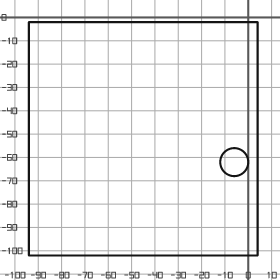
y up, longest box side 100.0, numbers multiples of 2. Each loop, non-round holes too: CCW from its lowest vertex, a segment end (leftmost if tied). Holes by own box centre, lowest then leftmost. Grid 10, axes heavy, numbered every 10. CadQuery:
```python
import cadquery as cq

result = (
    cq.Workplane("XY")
    .moveTo(-94.0, -102.0)
    .lineTo(4.0, -102.0)
    .lineTo(4.0, -2.0)
    .lineTo(-94.0, -2.0)
    .close()
    .moveTo(-6.0, -62.0)
    .circle(6.0)
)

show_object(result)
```